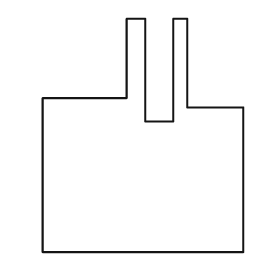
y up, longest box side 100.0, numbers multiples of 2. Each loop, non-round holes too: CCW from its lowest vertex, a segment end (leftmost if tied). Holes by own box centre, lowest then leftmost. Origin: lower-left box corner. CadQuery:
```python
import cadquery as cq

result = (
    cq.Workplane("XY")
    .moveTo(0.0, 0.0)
    .lineTo(86.0, 0.0)
    .lineTo(86.0, 62.0)
    .lineTo(62.0, 62.0)
    .lineTo(62.0, 100.0)
    .lineTo(56.0, 100.0)
    .lineTo(56.0, 56.0)
    .lineTo(44.0, 56.0)
    .lineTo(44.0, 100.0)
    .lineTo(36.0, 100.0)
    .lineTo(36.0, 66.0)
    .lineTo(0.0, 66.0)
    .close()
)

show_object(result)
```